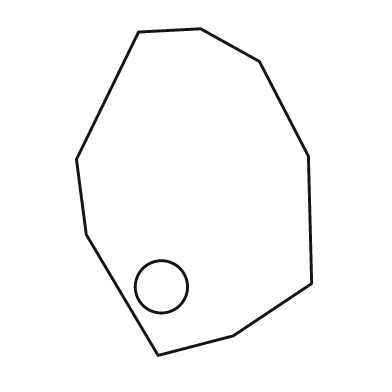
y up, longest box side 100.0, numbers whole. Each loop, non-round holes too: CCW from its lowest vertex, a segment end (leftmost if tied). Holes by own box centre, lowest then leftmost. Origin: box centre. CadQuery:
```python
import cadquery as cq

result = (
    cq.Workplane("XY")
    .moveTo(-11.0, -50.0)
    .lineTo(12.0, -44.0)
    .lineTo(36.0, -28.0)
    .lineTo(35.0, 11.0)
    .lineTo(20.0, 40.0)
    .lineTo(2.0, 50.0)
    .lineTo(-17.0, 49.0)
    .lineTo(-36.0, 10.0)
    .lineTo(-33.0, -13.0)
    .close()
    .moveTo(-10.0, -29.0)
    .circle(8.0)
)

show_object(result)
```